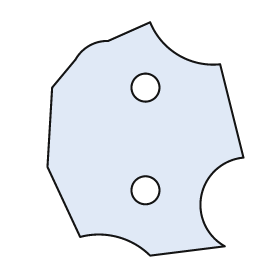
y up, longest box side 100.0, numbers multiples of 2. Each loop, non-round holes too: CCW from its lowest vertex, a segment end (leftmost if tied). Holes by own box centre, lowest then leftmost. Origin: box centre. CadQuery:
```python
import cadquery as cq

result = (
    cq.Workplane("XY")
    .moveTo(2.0, -50.0)
    .lineTo(34.0, -46.0)
    .threePointArc((24.0, -24.0), (42.0, -8.0))
    .lineTo(32.0, 32.0)
    .threePointArc((14.0, 36.0), (2.0, 50.0))
    .lineTo(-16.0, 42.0)
    .threePointArc((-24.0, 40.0), (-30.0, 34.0))
    .lineTo(-40.0, 22.0)
    .lineTo(-42.0, -12.0)
    .lineTo(-28.0, -42.0)
    .threePointArc((-12.0, -42.0), (2.0, -50.0))
    .close()
    .moveTo(0.0, -22.0)
    .circle(6.0)
    .moveTo(0.0, 22.0)
    .circle(6.0)
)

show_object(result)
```